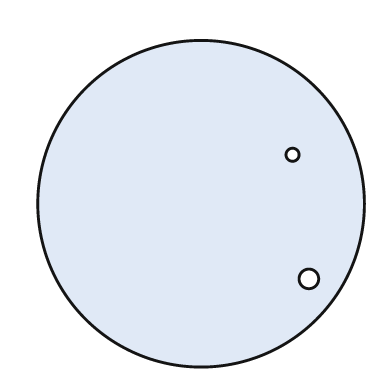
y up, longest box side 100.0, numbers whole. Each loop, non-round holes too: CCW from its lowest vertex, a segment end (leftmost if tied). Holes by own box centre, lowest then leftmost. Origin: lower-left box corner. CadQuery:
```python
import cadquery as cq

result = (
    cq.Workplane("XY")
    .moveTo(50.0, 50.0)
    .circle(50.0)
    .moveTo(83.0, 27.0)
    .circle(3.0)
    .moveTo(78.0, 65.0)
    .circle(2.0)
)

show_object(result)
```